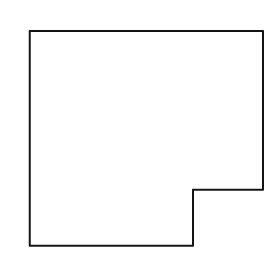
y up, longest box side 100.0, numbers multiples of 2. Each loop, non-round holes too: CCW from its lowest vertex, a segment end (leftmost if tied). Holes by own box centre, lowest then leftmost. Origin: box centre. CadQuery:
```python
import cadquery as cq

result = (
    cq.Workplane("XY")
    .moveTo(-50.0, -46.0)
    .lineTo(20.0, -46.0)
    .lineTo(20.0, -22.0)
    .lineTo(50.0, -22.0)
    .lineTo(50.0, 46.0)
    .lineTo(-50.0, 46.0)
    .close()
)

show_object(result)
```